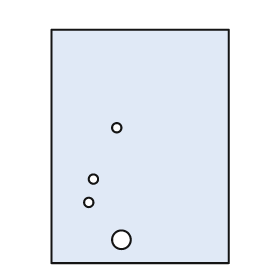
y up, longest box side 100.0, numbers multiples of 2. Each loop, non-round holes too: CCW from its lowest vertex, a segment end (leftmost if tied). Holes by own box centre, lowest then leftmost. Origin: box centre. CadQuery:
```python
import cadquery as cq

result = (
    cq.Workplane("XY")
    .moveTo(-38.0, -50.0)
    .lineTo(38.0, -50.0)
    .lineTo(38.0, 50.0)
    .lineTo(-38.0, 50.0)
    .close()
    .moveTo(-8.0, -40.0)
    .circle(4.0)
    .moveTo(-22.0, -24.0)
    .circle(2.0)
    .moveTo(-20.0, -14.0)
    .circle(2.0)
    .moveTo(-10.0, 8.0)
    .circle(2.0)
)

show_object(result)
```